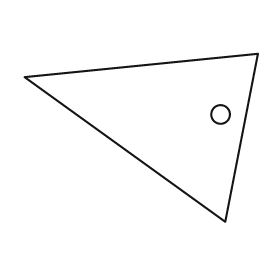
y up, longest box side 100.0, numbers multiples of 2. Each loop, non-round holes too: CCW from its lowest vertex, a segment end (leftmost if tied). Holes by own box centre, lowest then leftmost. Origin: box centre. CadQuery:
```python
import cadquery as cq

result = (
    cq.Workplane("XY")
    .moveTo(36.0, -36.0)
    .lineTo(50.0, 36.0)
    .lineTo(-50.0, 26.0)
    .close()
    .moveTo(34.0, 10.0)
    .circle(4.0)
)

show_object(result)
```